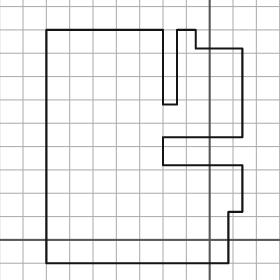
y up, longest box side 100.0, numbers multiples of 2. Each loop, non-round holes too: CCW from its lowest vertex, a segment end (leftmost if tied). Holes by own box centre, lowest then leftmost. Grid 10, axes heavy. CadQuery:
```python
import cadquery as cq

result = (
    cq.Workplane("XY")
    .moveTo(-70.0, -10.0)
    .lineTo(8.0, -10.0)
    .lineTo(8.0, 12.0)
    .lineTo(14.0, 12.0)
    .lineTo(14.0, 32.0)
    .lineTo(-20.0, 32.0)
    .lineTo(-20.0, 44.0)
    .lineTo(14.0, 44.0)
    .lineTo(14.0, 82.0)
    .lineTo(-6.0, 82.0)
    .lineTo(-6.0, 90.0)
    .lineTo(-14.0, 90.0)
    .lineTo(-14.0, 58.0)
    .lineTo(-20.0, 58.0)
    .lineTo(-20.0, 90.0)
    .lineTo(-70.0, 90.0)
    .close()
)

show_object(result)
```